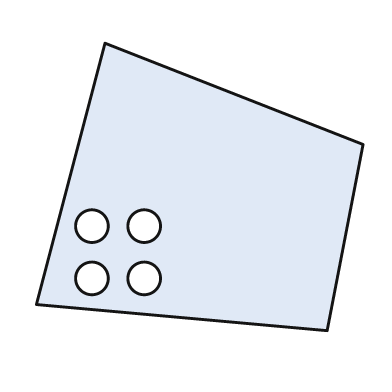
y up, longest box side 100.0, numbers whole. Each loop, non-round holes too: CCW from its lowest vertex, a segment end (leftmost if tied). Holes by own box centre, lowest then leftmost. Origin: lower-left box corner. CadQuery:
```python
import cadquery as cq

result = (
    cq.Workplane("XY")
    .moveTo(89.0, 0.0)
    .lineTo(100.0, 57.0)
    .lineTo(21.0, 88.0)
    .lineTo(0.0, 8.0)
    .close()
    .moveTo(17.0, 16.0)
    .circle(5.0)
    .moveTo(33.0, 16.0)
    .circle(5.0)
    .moveTo(17.0, 32.0)
    .circle(5.0)
    .moveTo(33.0, 32.0)
    .circle(5.0)
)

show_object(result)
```